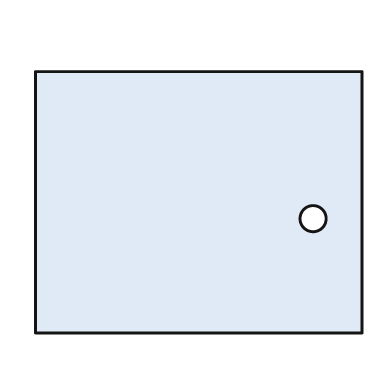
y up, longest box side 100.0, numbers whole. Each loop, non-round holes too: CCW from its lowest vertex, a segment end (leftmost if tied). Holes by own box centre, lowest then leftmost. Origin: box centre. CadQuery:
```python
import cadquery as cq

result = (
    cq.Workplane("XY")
    .moveTo(-50.0, -40.0)
    .lineTo(50.0, -40.0)
    .lineTo(50.0, 40.0)
    .lineTo(-50.0, 40.0)
    .close()
    .moveTo(35.0, -5.0)
    .circle(4.0)
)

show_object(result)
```